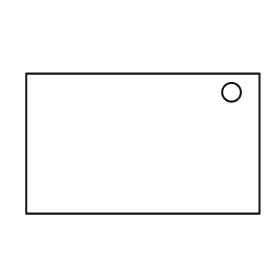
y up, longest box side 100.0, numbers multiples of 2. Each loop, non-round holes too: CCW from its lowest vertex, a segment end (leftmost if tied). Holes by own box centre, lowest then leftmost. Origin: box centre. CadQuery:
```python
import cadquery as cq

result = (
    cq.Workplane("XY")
    .moveTo(-50.0, -30.0)
    .lineTo(50.0, -30.0)
    .lineTo(50.0, 30.0)
    .lineTo(-50.0, 30.0)
    .close()
    .moveTo(38.0, 22.0)
    .circle(4.0)
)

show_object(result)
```